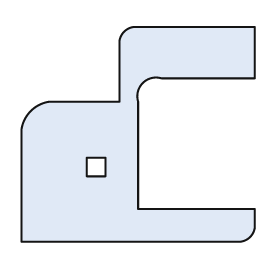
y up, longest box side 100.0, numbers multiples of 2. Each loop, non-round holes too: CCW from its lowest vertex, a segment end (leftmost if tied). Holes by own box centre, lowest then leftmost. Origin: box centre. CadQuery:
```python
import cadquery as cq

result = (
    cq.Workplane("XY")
    .moveTo(-50.0, -46.0)
    .lineTo(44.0, -46.0)
    .threePointArc((48.0, -44.0), (50.0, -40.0))
    .lineTo(50.0, -32.0)
    .lineTo(0.0, -32.0)
    .lineTo(0.0, 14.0)
    .threePointArc((2.0, 22.0), (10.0, 24.0))
    .lineTo(50.0, 24.0)
    .lineTo(50.0, 46.0)
    .lineTo(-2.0, 46.0)
    .threePointArc((-6.0, 44.0), (-8.0, 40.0))
    .lineTo(-8.0, 14.0)
    .lineTo(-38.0, 14.0)
    .threePointArc((-46.0, 10.0), (-50.0, 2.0))
    .close()
    .moveTo(-22.0, -18.0)
    .lineTo(-14.0, -18.0)
    .lineTo(-14.0, -10.0)
    .lineTo(-22.0, -10.0)
    .close()
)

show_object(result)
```